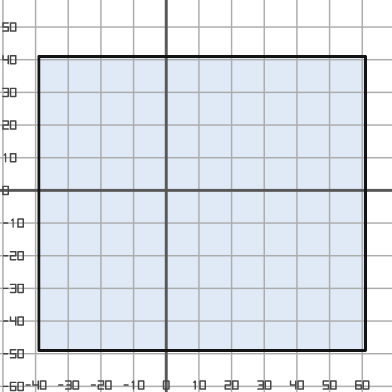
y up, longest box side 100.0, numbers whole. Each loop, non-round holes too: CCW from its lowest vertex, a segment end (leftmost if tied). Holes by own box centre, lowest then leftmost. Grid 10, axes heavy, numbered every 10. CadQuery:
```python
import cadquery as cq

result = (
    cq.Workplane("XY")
    .moveTo(-39.0, -49.0)
    .lineTo(61.0, -49.0)
    .lineTo(61.0, 41.0)
    .lineTo(-39.0, 41.0)
    .close()
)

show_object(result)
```